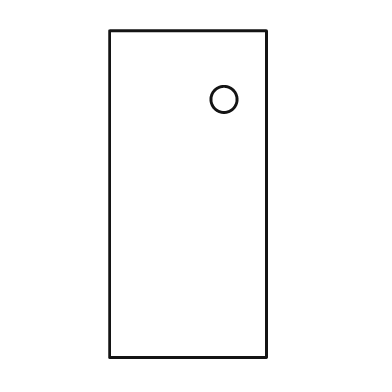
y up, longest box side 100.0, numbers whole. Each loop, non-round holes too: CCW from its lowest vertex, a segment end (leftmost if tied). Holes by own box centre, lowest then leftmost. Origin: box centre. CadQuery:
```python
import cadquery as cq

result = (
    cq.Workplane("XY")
    .moveTo(-24.0, -50.0)
    .lineTo(24.0, -50.0)
    .lineTo(24.0, 50.0)
    .lineTo(-24.0, 50.0)
    .close()
    .moveTo(11.0, 29.0)
    .circle(4.0)
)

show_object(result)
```